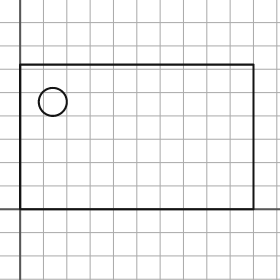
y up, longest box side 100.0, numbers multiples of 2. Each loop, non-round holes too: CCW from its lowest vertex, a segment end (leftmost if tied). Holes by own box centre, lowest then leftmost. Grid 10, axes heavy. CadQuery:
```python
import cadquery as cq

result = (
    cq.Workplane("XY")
    .moveTo(0.0, 0.0)
    .lineTo(100.0, 0.0)
    .lineTo(100.0, 62.0)
    .lineTo(0.0, 62.0)
    .close()
    .moveTo(14.0, 46.0)
    .circle(6.0)
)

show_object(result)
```